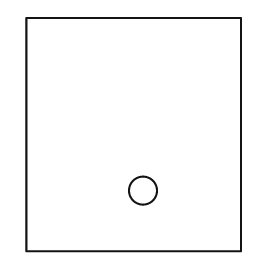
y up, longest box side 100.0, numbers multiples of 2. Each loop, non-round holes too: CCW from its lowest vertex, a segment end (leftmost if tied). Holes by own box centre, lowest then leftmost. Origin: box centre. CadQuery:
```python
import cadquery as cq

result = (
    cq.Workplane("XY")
    .moveTo(-46.0, -50.0)
    .lineTo(46.0, -50.0)
    .lineTo(46.0, 50.0)
    .lineTo(-46.0, 50.0)
    .close()
    .moveTo(4.0, -24.0)
    .circle(6.0)
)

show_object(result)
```